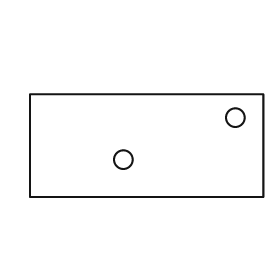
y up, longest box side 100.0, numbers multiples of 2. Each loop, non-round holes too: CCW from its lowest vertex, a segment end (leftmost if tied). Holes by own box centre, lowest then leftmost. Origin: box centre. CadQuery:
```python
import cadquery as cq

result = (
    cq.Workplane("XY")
    .moveTo(-50.0, -22.0)
    .lineTo(50.0, -22.0)
    .lineTo(50.0, 22.0)
    .lineTo(-50.0, 22.0)
    .close()
    .moveTo(-10.0, -6.0)
    .circle(4.0)
    .moveTo(38.0, 12.0)
    .circle(4.0)
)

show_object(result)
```